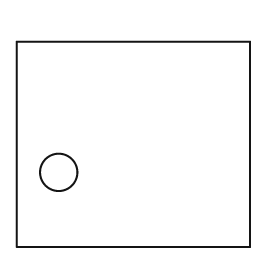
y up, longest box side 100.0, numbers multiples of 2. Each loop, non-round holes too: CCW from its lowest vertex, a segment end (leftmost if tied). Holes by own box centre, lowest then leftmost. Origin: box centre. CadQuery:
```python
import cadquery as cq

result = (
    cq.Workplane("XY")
    .moveTo(-50.0, -44.0)
    .lineTo(50.0, -44.0)
    .lineTo(50.0, 44.0)
    .lineTo(-50.0, 44.0)
    .close()
    .moveTo(-32.0, -12.0)
    .circle(8.0)
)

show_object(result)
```